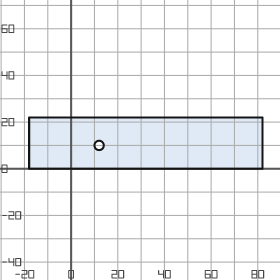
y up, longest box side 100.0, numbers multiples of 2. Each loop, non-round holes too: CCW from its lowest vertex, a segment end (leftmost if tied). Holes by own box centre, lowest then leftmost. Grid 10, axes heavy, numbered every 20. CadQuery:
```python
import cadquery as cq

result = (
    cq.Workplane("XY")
    .moveTo(-18.0, 0.0)
    .lineTo(82.0, 0.0)
    .lineTo(82.0, 22.0)
    .lineTo(-18.0, 22.0)
    .close()
    .moveTo(12.0, 10.0)
    .circle(2.0)
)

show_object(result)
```